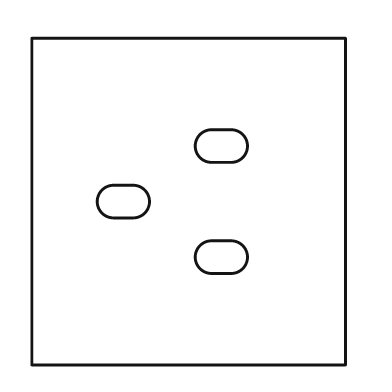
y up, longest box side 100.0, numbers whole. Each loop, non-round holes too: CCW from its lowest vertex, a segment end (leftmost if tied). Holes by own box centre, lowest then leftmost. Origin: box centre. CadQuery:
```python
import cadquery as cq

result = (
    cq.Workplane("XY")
    .moveTo(-48.0, -50.0)
    .lineTo(48.0, -50.0)
    .lineTo(48.0, 50.0)
    .lineTo(-48.0, 50.0)
    .close()
    .moveTo(7.0, -22.0)
    .lineTo(13.0, -22.0)
    .threePointArc((18.0, -17.0), (13.0, -12.0))
    .lineTo(7.0, -12.0)
    .threePointArc((2.0, -17.0), (7.0, -22.0))
    .close()
    .moveTo(-23.0, -5.0)
    .lineTo(-17.0, -5.0)
    .threePointArc((-12.0, 0.0), (-17.0, 5.0))
    .lineTo(-23.0, 5.0)
    .threePointArc((-28.0, 0.0), (-23.0, -5.0))
    .close()
    .moveTo(7.0, 12.0)
    .lineTo(13.0, 12.0)
    .threePointArc((18.0, 17.0), (13.0, 22.0))
    .lineTo(7.0, 22.0)
    .threePointArc((2.0, 17.0), (7.0, 12.0))
    .close()
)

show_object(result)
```